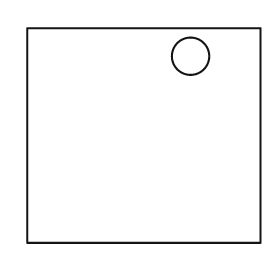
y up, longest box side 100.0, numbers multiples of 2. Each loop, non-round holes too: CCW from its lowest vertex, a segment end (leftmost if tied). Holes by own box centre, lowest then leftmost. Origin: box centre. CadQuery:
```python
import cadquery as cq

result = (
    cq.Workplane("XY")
    .moveTo(-50.0, -46.0)
    .lineTo(50.0, -46.0)
    .lineTo(50.0, 46.0)
    .lineTo(-50.0, 46.0)
    .close()
    .moveTo(20.0, 34.0)
    .circle(8.0)
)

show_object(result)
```